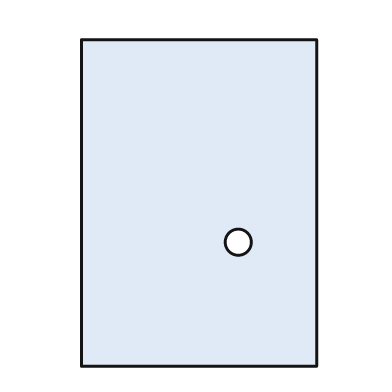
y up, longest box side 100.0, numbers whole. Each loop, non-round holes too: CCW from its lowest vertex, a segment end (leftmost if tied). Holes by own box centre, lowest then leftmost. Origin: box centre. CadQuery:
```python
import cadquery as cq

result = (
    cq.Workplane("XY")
    .moveTo(-36.0, -50.0)
    .lineTo(36.0, -50.0)
    .lineTo(36.0, 50.0)
    .lineTo(-36.0, 50.0)
    .close()
    .moveTo(12.0, -12.0)
    .circle(4.0)
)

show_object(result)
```